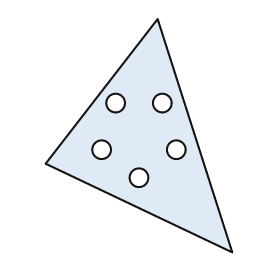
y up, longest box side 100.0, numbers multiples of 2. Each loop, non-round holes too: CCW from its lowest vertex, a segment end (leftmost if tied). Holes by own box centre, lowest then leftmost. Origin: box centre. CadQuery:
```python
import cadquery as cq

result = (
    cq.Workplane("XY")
    .moveTo(40.0, -50.0)
    .lineTo(8.0, 50.0)
    .lineTo(-40.0, -12.0)
    .close()
    .moveTo(0.0, -18.0)
    .circle(4.0)
    .moveTo(-16.0, -6.0)
    .circle(4.0)
    .moveTo(16.0, -6.0)
    .circle(4.0)
    .moveTo(-10.0, 14.0)
    .circle(4.0)
    .moveTo(10.0, 14.0)
    .circle(4.0)
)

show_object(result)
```